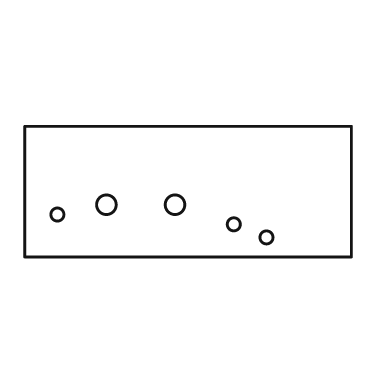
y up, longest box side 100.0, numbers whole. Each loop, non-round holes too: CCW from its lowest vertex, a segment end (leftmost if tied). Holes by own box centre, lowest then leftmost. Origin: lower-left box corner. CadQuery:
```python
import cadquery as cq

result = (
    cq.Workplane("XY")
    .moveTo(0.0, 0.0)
    .lineTo(100.0, 0.0)
    .lineTo(100.0, 40.0)
    .lineTo(0.0, 40.0)
    .close()
    .moveTo(74.0, 6.0)
    .circle(2.0)
    .moveTo(64.0, 10.0)
    .circle(2.0)
    .moveTo(10.0, 13.0)
    .circle(2.0)
    .moveTo(25.0, 16.0)
    .circle(3.0)
    .moveTo(46.0, 16.0)
    .circle(3.0)
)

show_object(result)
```